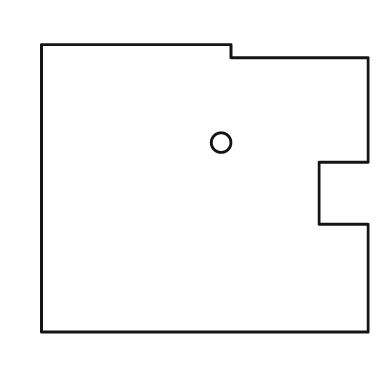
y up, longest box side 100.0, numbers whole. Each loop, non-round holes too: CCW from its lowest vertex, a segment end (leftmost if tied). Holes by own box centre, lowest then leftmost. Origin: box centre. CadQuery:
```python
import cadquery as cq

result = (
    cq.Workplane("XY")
    .moveTo(-50.0, -44.0)
    .lineTo(50.0, -44.0)
    .lineTo(50.0, -11.0)
    .lineTo(35.0, -11.0)
    .lineTo(35.0, 8.0)
    .lineTo(50.0, 8.0)
    .lineTo(50.0, 40.0)
    .lineTo(8.0, 40.0)
    .lineTo(8.0, 44.0)
    .lineTo(-50.0, 44.0)
    .close()
    .moveTo(5.0, 14.0)
    .circle(3.0)
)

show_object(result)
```